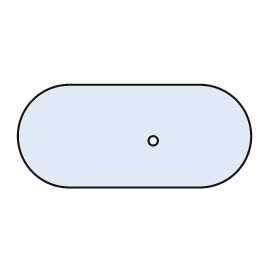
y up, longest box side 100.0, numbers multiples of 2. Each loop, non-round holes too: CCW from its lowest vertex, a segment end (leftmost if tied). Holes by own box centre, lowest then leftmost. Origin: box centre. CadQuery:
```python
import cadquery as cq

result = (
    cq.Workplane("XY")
    .moveTo(-28.0, -22.0)
    .lineTo(28.0, -22.0)
    .threePointArc((50.0, 0.0), (28.0, 22.0))
    .lineTo(-28.0, 22.0)
    .threePointArc((-50.0, 0.0), (-28.0, -22.0))
    .close()
    .moveTo(8.0, -2.0)
    .circle(2.0)
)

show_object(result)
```